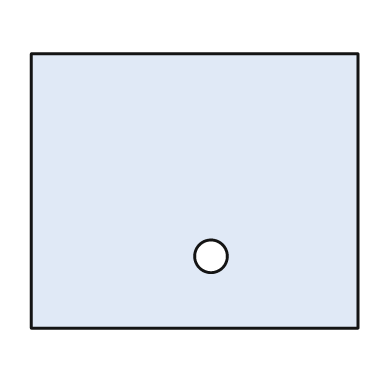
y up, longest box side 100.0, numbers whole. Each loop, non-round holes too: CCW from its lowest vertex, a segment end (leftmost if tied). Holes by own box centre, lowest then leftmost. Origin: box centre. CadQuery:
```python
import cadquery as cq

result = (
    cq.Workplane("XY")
    .moveTo(-50.0, -42.0)
    .lineTo(50.0, -42.0)
    .lineTo(50.0, 42.0)
    .lineTo(-50.0, 42.0)
    .close()
    .moveTo(5.0, -20.0)
    .circle(5.0)
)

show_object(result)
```